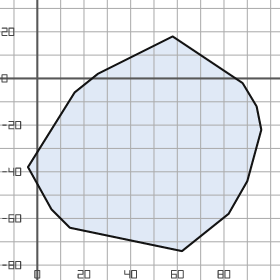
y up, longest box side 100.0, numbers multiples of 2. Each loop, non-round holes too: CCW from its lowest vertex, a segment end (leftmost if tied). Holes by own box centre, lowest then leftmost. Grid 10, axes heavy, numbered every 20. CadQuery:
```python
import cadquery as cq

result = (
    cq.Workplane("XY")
    .moveTo(62.0, -74.0)
    .lineTo(82.0, -58.0)
    .lineTo(90.0, -44.0)
    .lineTo(96.0, -22.0)
    .lineTo(94.0, -12.0)
    .lineTo(88.0, -2.0)
    .lineTo(58.0, 18.0)
    .lineTo(26.0, 2.0)
    .lineTo(16.0, -6.0)
    .lineTo(-4.0, -38.0)
    .lineTo(6.0, -56.0)
    .lineTo(14.0, -64.0)
    .close()
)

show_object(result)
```